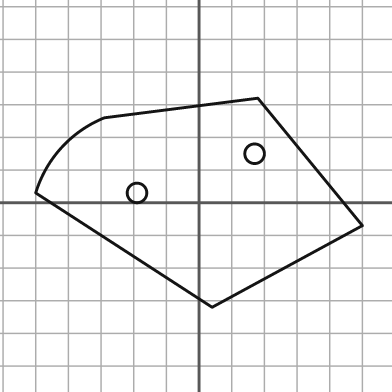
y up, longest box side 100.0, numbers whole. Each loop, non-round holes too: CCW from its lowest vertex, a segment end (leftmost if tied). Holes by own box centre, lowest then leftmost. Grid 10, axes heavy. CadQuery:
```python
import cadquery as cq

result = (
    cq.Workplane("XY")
    .moveTo(4.0, -32.0)
    .lineTo(50.0, -7.0)
    .lineTo(18.0, 32.0)
    .lineTo(-29.0, 26.0)
    .threePointArc((-42.0, 17.0), (-50.0, 3.0))
    .close()
    .moveTo(-19.0, 3.0)
    .circle(3.0)
    .moveTo(17.0, 15.0)
    .circle(3.0)
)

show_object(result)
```